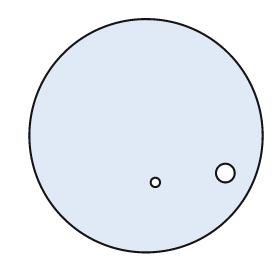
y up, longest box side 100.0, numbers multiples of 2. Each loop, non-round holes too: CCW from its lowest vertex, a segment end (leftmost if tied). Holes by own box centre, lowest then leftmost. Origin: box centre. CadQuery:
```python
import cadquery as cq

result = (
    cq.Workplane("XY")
    .moveTo(0.0, 0.0)
    .circle(50.0)
    .moveTo(4.0, -20.0)
    .circle(2.0)
    .moveTo(34.0, -16.0)
    .circle(4.0)
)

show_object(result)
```